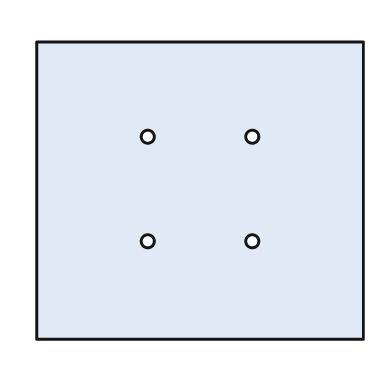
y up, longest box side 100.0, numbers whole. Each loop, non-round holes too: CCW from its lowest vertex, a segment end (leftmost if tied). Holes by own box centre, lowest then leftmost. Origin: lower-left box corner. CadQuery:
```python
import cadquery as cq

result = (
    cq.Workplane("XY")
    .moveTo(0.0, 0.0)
    .lineTo(100.0, 0.0)
    .lineTo(100.0, 91.0)
    .lineTo(0.0, 91.0)
    .close()
    .moveTo(34.0, 30.0)
    .circle(2.0)
    .moveTo(66.0, 30.0)
    .circle(2.0)
    .moveTo(34.0, 62.0)
    .circle(2.0)
    .moveTo(66.0, 62.0)
    .circle(2.0)
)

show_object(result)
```